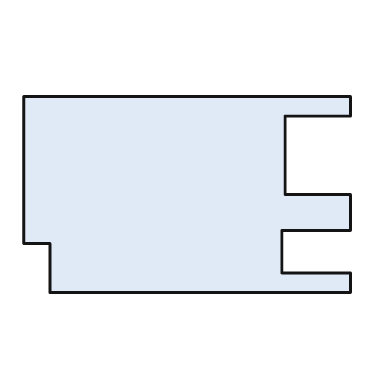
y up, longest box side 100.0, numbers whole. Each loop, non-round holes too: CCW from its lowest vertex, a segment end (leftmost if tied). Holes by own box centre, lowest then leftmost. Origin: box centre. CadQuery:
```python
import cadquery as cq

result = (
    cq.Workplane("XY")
    .moveTo(-42.0, -30.0)
    .lineTo(50.0, -30.0)
    .lineTo(50.0, -24.0)
    .lineTo(29.0, -24.0)
    .lineTo(29.0, -11.0)
    .lineTo(50.0, -11.0)
    .lineTo(50.0, 0.0)
    .lineTo(30.0, 0.0)
    .lineTo(30.0, 24.0)
    .lineTo(50.0, 24.0)
    .lineTo(50.0, 30.0)
    .lineTo(-50.0, 30.0)
    .lineTo(-50.0, -15.0)
    .lineTo(-42.0, -15.0)
    .close()
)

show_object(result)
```